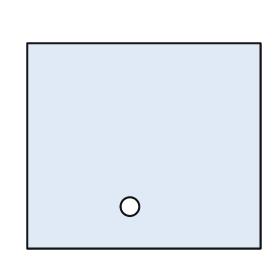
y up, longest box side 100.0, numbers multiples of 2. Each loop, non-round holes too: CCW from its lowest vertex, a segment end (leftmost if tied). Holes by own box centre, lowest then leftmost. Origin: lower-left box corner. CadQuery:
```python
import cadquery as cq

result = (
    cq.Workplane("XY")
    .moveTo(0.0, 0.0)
    .lineTo(100.0, 0.0)
    .lineTo(100.0, 88.0)
    .lineTo(0.0, 88.0)
    .close()
    .moveTo(44.0, 18.0)
    .circle(4.0)
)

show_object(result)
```